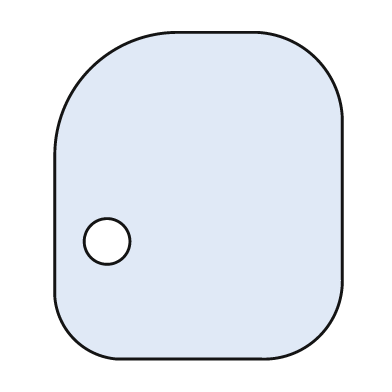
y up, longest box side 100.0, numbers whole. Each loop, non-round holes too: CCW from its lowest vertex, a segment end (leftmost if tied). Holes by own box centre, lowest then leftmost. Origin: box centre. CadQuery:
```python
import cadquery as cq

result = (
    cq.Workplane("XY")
    .moveTo(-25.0, -50.0)
    .lineTo(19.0, -50.0)
    .threePointArc((37.0, -43.0), (44.0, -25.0))
    .lineTo(44.0, 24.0)
    .threePointArc((36.0, 42.0), (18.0, 50.0))
    .lineTo(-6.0, 50.0)
    .threePointArc((-33.0, 39.0), (-44.0, 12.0))
    .lineTo(-44.0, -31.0)
    .threePointArc((-38.0, -44.0), (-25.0, -50.0))
    .close()
    .moveTo(-28.0, -14.0)
    .circle(7.0)
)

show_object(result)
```